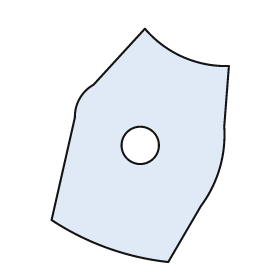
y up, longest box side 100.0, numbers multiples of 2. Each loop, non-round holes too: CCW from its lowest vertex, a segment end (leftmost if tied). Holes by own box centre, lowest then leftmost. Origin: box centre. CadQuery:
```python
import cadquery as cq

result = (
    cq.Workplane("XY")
    .moveTo(12.0, -50.0)
    .lineTo(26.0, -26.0)
    .threePointArc((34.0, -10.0), (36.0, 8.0))
    .lineTo(38.0, 34.0)
    .threePointArc((18.0, 38.0), (2.0, 50.0))
    .lineTo(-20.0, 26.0)
    .threePointArc((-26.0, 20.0), (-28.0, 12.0))
    .lineTo(-38.0, -32.0)
    .threePointArc((-14.0, -44.0), (12.0, -50.0))
    .close()
    .moveTo(0.0, 0.0)
    .circle(8.0)
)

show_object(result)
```